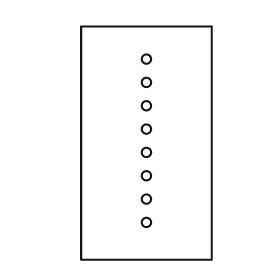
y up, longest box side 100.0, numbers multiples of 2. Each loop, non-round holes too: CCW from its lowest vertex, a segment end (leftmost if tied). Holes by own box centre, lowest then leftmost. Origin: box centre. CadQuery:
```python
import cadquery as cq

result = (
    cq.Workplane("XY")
    .moveTo(-28.0, -50.0)
    .lineTo(28.0, -50.0)
    .lineTo(28.0, 50.0)
    .lineTo(-28.0, 50.0)
    .close()
    .moveTo(0.0, -34.0)
    .circle(2.0)
    .moveTo(0.0, -24.0)
    .circle(2.0)
    .moveTo(0.0, -14.0)
    .circle(2.0)
    .moveTo(0.0, -4.0)
    .circle(2.0)
    .moveTo(0.0, 6.0)
    .circle(2.0)
    .moveTo(0.0, 16.0)
    .circle(2.0)
    .moveTo(0.0, 26.0)
    .circle(2.0)
    .moveTo(0.0, 36.0)
    .circle(2.0)
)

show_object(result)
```